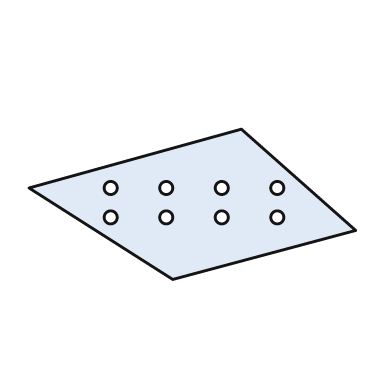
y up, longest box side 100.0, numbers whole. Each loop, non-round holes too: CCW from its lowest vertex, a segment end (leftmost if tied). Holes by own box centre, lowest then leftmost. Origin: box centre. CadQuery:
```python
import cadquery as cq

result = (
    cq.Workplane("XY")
    .moveTo(-6.0, -23.0)
    .lineTo(50.0, -8.0)
    .lineTo(15.0, 23.0)
    .lineTo(-50.0, 5.0)
    .close()
    .moveTo(-25.0, -4.0)
    .circle(2.0)
    .moveTo(-8.0, -4.0)
    .circle(2.0)
    .moveTo(9.0, -4.0)
    .circle(2.0)
    .moveTo(26.0, -4.0)
    .circle(2.0)
    .moveTo(-25.0, 5.0)
    .circle(2.0)
    .moveTo(-8.0, 5.0)
    .circle(2.0)
    .moveTo(9.0, 5.0)
    .circle(2.0)
    .moveTo(26.0, 5.0)
    .circle(2.0)
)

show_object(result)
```